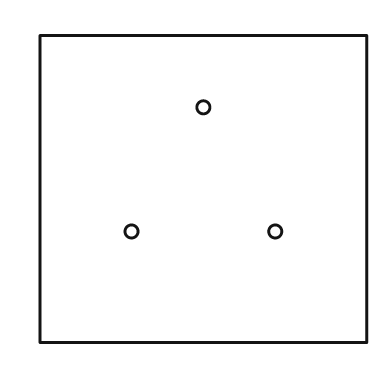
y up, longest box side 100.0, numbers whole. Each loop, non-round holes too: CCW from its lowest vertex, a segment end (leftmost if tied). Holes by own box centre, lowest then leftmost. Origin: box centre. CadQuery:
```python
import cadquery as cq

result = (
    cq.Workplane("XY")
    .moveTo(-50.0, -47.0)
    .lineTo(50.0, -47.0)
    .lineTo(50.0, 47.0)
    .lineTo(-50.0, 47.0)
    .close()
    .moveTo(-22.0, -13.0)
    .circle(2.0)
    .moveTo(22.0, -13.0)
    .circle(2.0)
    .moveTo(0.0, 25.0)
    .circle(2.0)
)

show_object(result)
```